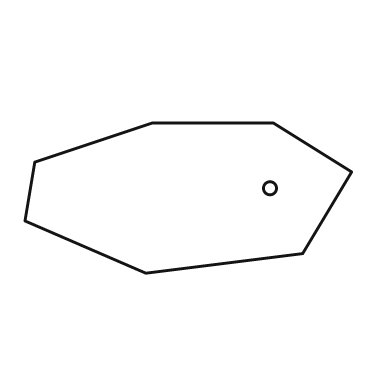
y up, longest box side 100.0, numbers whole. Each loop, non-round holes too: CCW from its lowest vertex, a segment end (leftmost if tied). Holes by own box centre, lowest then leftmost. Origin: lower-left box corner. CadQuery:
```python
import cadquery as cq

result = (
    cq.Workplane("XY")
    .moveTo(37.0, 0.0)
    .lineTo(85.0, 6.0)
    .lineTo(100.0, 31.0)
    .lineTo(76.0, 46.0)
    .lineTo(39.0, 46.0)
    .lineTo(3.0, 34.0)
    .lineTo(0.0, 16.0)
    .close()
    .moveTo(75.0, 26.0)
    .circle(2.0)
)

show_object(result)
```